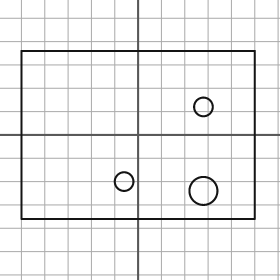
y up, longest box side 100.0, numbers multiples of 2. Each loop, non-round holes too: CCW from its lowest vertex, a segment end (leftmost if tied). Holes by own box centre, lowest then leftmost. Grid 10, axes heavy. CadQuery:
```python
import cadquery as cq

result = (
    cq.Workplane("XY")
    .moveTo(-50.0, -36.0)
    .lineTo(50.0, -36.0)
    .lineTo(50.0, 36.0)
    .lineTo(-50.0, 36.0)
    .close()
    .moveTo(28.0, -24.0)
    .circle(6.0)
    .moveTo(-6.0, -20.0)
    .circle(4.0)
    .moveTo(28.0, 12.0)
    .circle(4.0)
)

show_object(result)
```